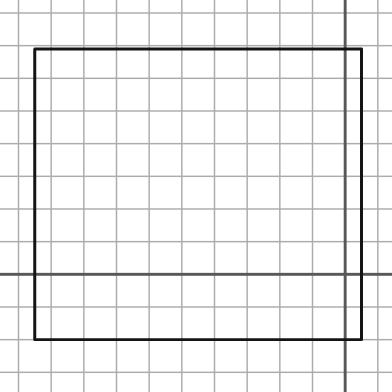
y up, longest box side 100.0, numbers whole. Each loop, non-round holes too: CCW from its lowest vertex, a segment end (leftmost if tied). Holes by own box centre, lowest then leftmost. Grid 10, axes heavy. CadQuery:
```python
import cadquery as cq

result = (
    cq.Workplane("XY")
    .moveTo(-95.0, -20.0)
    .lineTo(5.0, -20.0)
    .lineTo(5.0, 69.0)
    .lineTo(-95.0, 69.0)
    .close()
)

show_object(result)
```